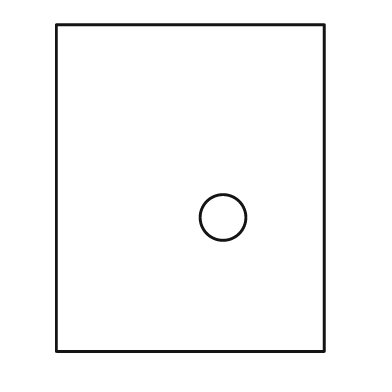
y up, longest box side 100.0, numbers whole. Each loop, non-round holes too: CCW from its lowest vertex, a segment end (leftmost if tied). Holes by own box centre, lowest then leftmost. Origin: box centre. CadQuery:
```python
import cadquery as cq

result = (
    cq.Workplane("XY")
    .moveTo(-41.0, -50.0)
    .lineTo(41.0, -50.0)
    .lineTo(41.0, 50.0)
    .lineTo(-41.0, 50.0)
    .close()
    .moveTo(10.0, -9.0)
    .circle(7.0)
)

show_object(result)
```